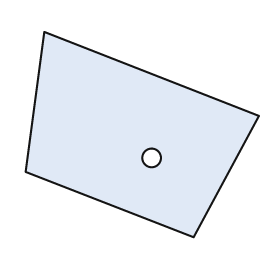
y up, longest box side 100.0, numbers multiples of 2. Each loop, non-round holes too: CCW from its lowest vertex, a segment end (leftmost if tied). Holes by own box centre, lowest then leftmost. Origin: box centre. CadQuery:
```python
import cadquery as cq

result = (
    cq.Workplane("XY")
    .moveTo(22.0, -44.0)
    .lineTo(50.0, 8.0)
    .lineTo(-42.0, 44.0)
    .lineTo(-50.0, -16.0)
    .close()
    .moveTo(4.0, -10.0)
    .circle(4.0)
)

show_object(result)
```